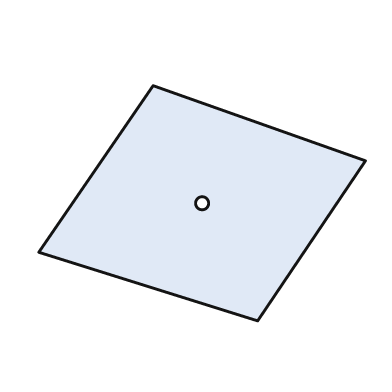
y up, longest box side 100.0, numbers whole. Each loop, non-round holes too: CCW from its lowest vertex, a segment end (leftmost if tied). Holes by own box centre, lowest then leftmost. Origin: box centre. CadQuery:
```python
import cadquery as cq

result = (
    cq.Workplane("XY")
    .moveTo(17.0, -36.0)
    .lineTo(50.0, 13.0)
    .lineTo(-15.0, 36.0)
    .lineTo(-50.0, -15.0)
    .close()
    .moveTo(0.0, 0.0)
    .circle(2.0)
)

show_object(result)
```